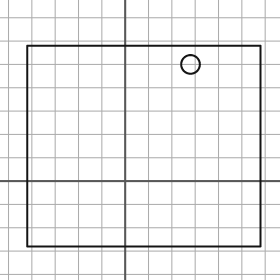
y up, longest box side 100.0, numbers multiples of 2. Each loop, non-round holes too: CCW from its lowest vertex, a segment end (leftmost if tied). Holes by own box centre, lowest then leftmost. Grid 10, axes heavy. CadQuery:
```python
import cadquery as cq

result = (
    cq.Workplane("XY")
    .moveTo(-42.0, -28.0)
    .lineTo(58.0, -28.0)
    .lineTo(58.0, 58.0)
    .lineTo(-42.0, 58.0)
    .close()
    .moveTo(28.0, 50.0)
    .circle(4.0)
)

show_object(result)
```